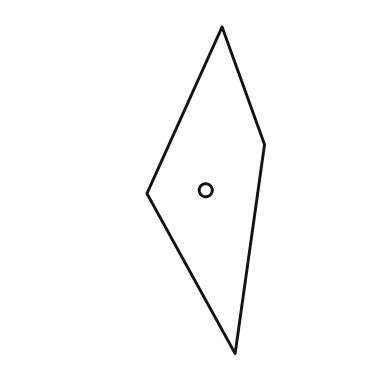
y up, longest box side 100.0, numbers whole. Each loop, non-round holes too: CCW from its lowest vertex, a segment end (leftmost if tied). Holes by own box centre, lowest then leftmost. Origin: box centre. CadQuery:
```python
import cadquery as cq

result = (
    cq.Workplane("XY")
    .moveTo(9.0, -50.0)
    .lineTo(18.0, 14.0)
    .lineTo(5.0, 50.0)
    .lineTo(-18.0, -1.0)
    .close()
    .moveTo(0.0, 0.0)
    .circle(2.0)
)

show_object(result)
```